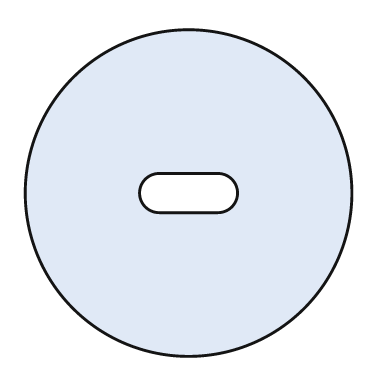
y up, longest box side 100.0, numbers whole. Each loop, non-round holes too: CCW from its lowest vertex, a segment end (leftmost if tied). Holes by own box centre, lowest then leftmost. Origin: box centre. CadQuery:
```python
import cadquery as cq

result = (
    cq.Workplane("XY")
    .moveTo(0.0, 0.0)
    .circle(50.0)
    .moveTo(-9.0, -6.0)
    .lineTo(9.0, -6.0)
    .threePointArc((15.0, 0.0), (9.0, 6.0))
    .lineTo(-9.0, 6.0)
    .threePointArc((-15.0, 0.0), (-9.0, -6.0))
    .close()
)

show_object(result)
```